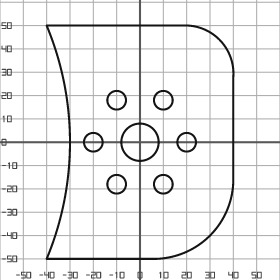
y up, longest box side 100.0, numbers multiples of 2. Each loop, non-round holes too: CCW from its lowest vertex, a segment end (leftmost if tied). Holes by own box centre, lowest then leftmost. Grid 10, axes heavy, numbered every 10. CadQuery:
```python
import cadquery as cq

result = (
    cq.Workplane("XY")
    .moveTo(-40.0, -50.0)
    .lineTo(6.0, -50.0)
    .threePointArc((30.0, -40.0), (40.0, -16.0))
    .lineTo(40.0, 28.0)
    .threePointArc((34.0, 44.0), (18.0, 50.0))
    .lineTo(-40.0, 50.0)
    .threePointArc((-30.0, 0.0), (-40.0, -50.0))
    .close()
    .moveTo(-10.0, -18.0)
    .circle(4.0)
    .moveTo(10.0, -18.0)
    .circle(4.0)
    .moveTo(-20.0, 0.0)
    .circle(4.0)
    .moveTo(0.0, 0.0)
    .circle(8.0)
    .moveTo(20.0, 0.0)
    .circle(4.0)
    .moveTo(-10.0, 18.0)
    .circle(4.0)
    .moveTo(10.0, 18.0)
    .circle(4.0)
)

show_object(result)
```